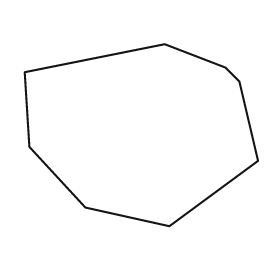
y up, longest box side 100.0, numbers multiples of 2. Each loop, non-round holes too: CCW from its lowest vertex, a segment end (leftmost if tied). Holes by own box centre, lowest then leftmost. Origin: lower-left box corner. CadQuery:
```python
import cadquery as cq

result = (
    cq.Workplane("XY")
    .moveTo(62.0, 0.0)
    .lineTo(100.0, 28.0)
    .lineTo(92.0, 62.0)
    .lineTo(86.0, 68.0)
    .lineTo(60.0, 78.0)
    .lineTo(0.0, 66.0)
    .lineTo(2.0, 34.0)
    .lineTo(26.0, 8.0)
    .close()
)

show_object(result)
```